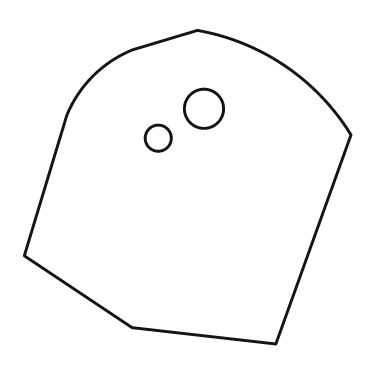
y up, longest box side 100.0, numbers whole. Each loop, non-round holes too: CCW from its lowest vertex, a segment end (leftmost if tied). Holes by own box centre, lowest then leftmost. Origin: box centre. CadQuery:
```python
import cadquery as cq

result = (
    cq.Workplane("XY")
    .moveTo(27.0, -48.0)
    .lineTo(50.0, 16.0)
    .threePointArc((30.0, 37.0), (3.0, 48.0))
    .lineTo(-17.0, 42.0)
    .threePointArc((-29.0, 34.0), (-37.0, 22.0))
    .lineTo(-50.0, -21.0)
    .lineTo(-17.0, -43.0)
    .close()
    .moveTo(-9.0, 15.0)
    .circle(4.0)
    .moveTo(5.0, 24.0)
    .circle(6.0)
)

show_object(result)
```